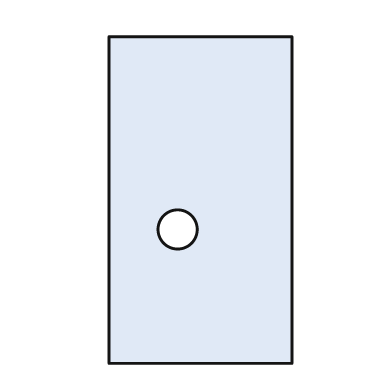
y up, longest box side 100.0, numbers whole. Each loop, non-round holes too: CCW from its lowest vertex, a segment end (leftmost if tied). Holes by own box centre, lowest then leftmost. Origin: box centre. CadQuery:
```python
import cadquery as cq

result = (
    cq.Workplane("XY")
    .moveTo(-28.0, -50.0)
    .lineTo(28.0, -50.0)
    .lineTo(28.0, 50.0)
    .lineTo(-28.0, 50.0)
    .close()
    .moveTo(-7.0, -9.0)
    .circle(6.0)
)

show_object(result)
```